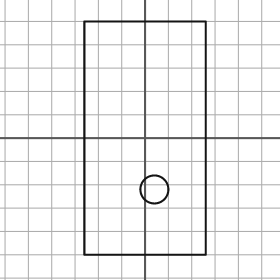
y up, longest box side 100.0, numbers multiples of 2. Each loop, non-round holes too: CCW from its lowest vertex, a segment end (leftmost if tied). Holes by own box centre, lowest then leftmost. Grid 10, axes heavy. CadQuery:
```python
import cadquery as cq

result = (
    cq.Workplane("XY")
    .moveTo(-26.0, -50.0)
    .lineTo(26.0, -50.0)
    .lineTo(26.0, 50.0)
    .lineTo(-26.0, 50.0)
    .close()
    .moveTo(4.0, -22.0)
    .circle(6.0)
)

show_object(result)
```